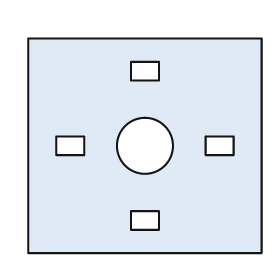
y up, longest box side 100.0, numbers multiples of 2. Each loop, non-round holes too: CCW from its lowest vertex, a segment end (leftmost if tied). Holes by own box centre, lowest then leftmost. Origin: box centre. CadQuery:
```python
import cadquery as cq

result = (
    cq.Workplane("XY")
    .moveTo(-50.0, -46.0)
    .lineTo(50.0, -46.0)
    .lineTo(50.0, 46.0)
    .lineTo(-50.0, 46.0)
    .close()
    .moveTo(-6.0, -36.0)
    .lineTo(6.0, -36.0)
    .lineTo(6.0, -28.0)
    .lineTo(-6.0, -28.0)
    .close()
    .moveTo(-38.0, -4.0)
    .lineTo(-26.0, -4.0)
    .lineTo(-26.0, 4.0)
    .lineTo(-38.0, 4.0)
    .close()
    .moveTo(0.0, 0.0)
    .circle(12.0)
    .moveTo(26.0, -4.0)
    .lineTo(38.0, -4.0)
    .lineTo(38.0, 4.0)
    .lineTo(26.0, 4.0)
    .close()
    .moveTo(-6.0, 28.0)
    .lineTo(6.0, 28.0)
    .lineTo(6.0, 36.0)
    .lineTo(-6.0, 36.0)
    .close()
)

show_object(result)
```